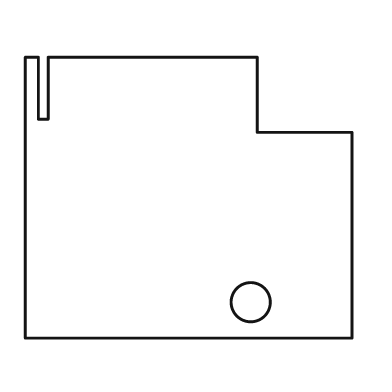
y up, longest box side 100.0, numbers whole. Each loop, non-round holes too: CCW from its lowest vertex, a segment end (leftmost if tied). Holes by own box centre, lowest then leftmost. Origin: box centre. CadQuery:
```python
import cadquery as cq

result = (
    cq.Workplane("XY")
    .moveTo(-50.0, -43.0)
    .lineTo(50.0, -43.0)
    .lineTo(50.0, 20.0)
    .lineTo(21.0, 20.0)
    .lineTo(21.0, 43.0)
    .lineTo(-43.0, 43.0)
    .lineTo(-43.0, 24.0)
    .lineTo(-46.0, 24.0)
    .lineTo(-46.0, 43.0)
    .lineTo(-50.0, 43.0)
    .close()
    .moveTo(19.0, -32.0)
    .circle(6.0)
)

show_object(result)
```